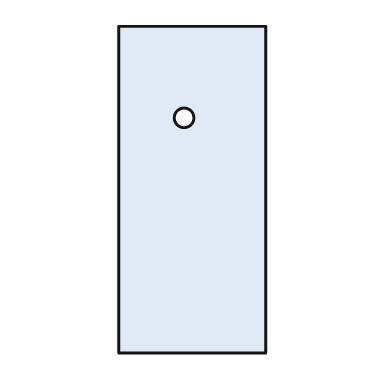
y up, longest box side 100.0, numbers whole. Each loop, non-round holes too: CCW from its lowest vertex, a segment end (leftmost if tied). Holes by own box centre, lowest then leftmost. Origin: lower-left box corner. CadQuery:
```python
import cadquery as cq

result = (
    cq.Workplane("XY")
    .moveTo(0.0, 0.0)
    .lineTo(45.0, 0.0)
    .lineTo(45.0, 100.0)
    .lineTo(0.0, 100.0)
    .close()
    .moveTo(20.0, 72.0)
    .circle(3.0)
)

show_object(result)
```